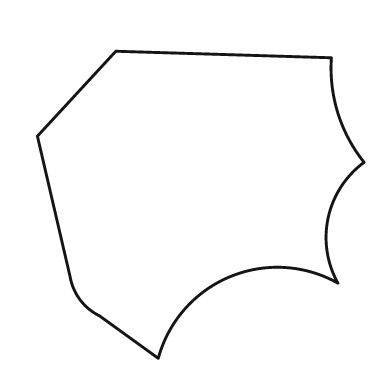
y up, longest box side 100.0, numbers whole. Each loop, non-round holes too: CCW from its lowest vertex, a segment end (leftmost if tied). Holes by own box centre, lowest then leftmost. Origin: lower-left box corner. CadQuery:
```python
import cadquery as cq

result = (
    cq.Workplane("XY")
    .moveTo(37.0, 0.0)
    .threePointArc((59.0, 25.0), (92.0, 23.0))
    .threePointArc((89.0, 43.0), (100.0, 60.0))
    .threePointArc((92.0, 75.0), (90.0, 92.0))
    .lineTo(24.0, 94.0)
    .lineTo(0.0, 68.0)
    .lineTo(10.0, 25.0)
    .threePointArc((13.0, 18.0), (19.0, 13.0))
    .close()
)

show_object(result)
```